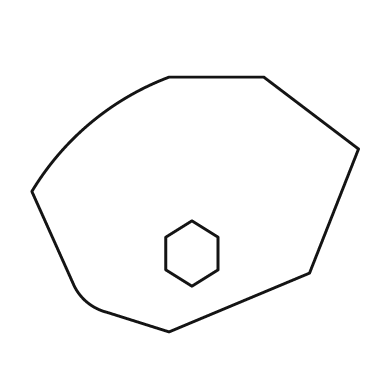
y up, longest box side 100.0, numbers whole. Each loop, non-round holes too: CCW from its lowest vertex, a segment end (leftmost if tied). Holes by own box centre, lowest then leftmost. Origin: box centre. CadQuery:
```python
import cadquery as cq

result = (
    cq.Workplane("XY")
    .moveTo(-8.0, -39.0)
    .lineTo(35.0, -21.0)
    .lineTo(50.0, 17.0)
    .lineTo(21.0, 39.0)
    .lineTo(-8.0, 39.0)
    .threePointArc((-32.0, 25.0), (-50.0, 4.0))
    .lineTo(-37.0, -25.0)
    .threePointArc((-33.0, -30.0), (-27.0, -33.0))
    .close()
    .moveTo(-1.0, -25.0)
    .lineTo(7.0, -20.0)
    .lineTo(7.0, -10.0)
    .lineTo(-1.0, -5.0)
    .lineTo(-9.0, -10.0)
    .lineTo(-9.0, -20.0)
    .close()
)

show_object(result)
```